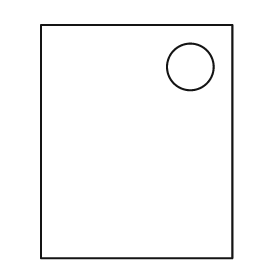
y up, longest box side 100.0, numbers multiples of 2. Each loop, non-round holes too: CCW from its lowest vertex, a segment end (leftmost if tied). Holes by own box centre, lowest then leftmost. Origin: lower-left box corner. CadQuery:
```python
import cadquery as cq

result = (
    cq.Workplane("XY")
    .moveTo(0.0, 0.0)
    .lineTo(82.0, 0.0)
    .lineTo(82.0, 100.0)
    .lineTo(0.0, 100.0)
    .close()
    .moveTo(64.0, 82.0)
    .circle(10.0)
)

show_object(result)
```